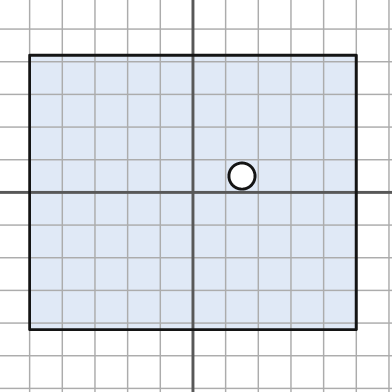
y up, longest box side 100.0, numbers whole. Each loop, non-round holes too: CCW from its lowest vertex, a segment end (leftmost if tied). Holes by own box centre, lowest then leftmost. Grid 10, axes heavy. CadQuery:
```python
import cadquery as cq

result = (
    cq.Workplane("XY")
    .moveTo(-50.0, -42.0)
    .lineTo(50.0, -42.0)
    .lineTo(50.0, 42.0)
    .lineTo(-50.0, 42.0)
    .close()
    .moveTo(15.0, 5.0)
    .circle(4.0)
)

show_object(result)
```